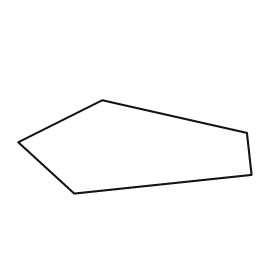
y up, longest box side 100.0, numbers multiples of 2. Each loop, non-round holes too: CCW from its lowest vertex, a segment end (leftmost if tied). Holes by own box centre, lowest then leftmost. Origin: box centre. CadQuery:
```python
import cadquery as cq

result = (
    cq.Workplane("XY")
    .moveTo(-26.0, -20.0)
    .lineTo(50.0, -12.0)
    .lineTo(48.0, 6.0)
    .lineTo(-14.0, 20.0)
    .lineTo(-50.0, 2.0)
    .close()
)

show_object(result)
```